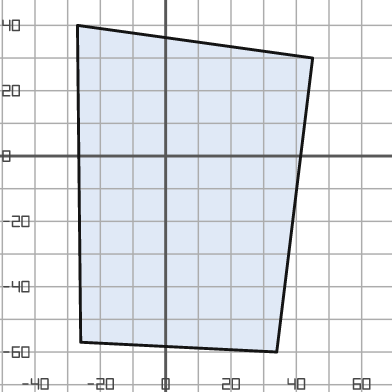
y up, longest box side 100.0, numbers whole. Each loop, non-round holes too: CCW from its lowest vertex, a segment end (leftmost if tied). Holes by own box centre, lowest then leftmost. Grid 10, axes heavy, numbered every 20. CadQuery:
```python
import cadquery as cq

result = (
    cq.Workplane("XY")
    .moveTo(34.0, -60.0)
    .lineTo(45.0, 30.0)
    .lineTo(-27.0, 40.0)
    .lineTo(-26.0, -57.0)
    .close()
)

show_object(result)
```